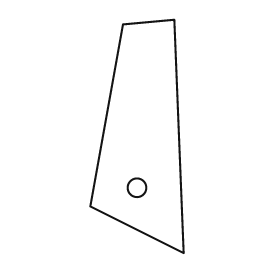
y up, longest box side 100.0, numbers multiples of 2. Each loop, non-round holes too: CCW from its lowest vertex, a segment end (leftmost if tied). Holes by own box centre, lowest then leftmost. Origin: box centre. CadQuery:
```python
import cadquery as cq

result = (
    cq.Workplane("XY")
    .moveTo(20.0, -50.0)
    .lineTo(16.0, 50.0)
    .lineTo(-6.0, 48.0)
    .lineTo(-20.0, -30.0)
    .close()
    .moveTo(0.0, -22.0)
    .circle(4.0)
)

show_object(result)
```